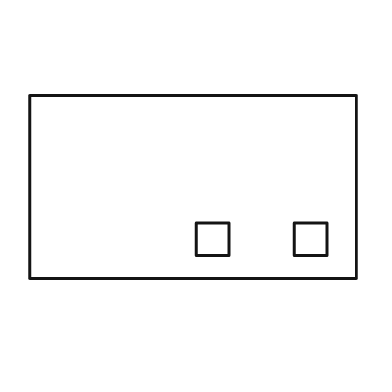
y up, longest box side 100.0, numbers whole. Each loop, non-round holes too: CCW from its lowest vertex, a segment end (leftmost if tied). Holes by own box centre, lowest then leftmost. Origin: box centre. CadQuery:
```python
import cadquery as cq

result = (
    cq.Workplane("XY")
    .moveTo(-50.0, -28.0)
    .lineTo(50.0, -28.0)
    .lineTo(50.0, 28.0)
    .lineTo(-50.0, 28.0)
    .close()
    .moveTo(1.0, -21.0)
    .lineTo(11.0, -21.0)
    .lineTo(11.0, -11.0)
    .lineTo(1.0, -11.0)
    .close()
    .moveTo(31.0, -21.0)
    .lineTo(41.0, -21.0)
    .lineTo(41.0, -11.0)
    .lineTo(31.0, -11.0)
    .close()
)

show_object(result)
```